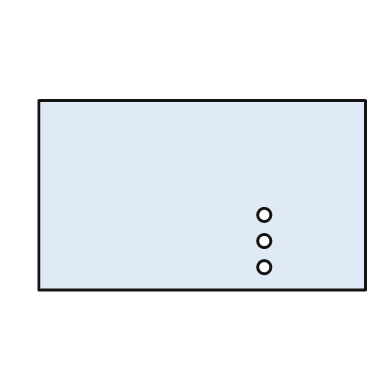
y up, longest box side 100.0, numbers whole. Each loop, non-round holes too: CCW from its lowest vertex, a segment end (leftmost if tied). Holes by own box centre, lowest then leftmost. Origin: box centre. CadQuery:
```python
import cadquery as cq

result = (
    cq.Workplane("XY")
    .moveTo(-50.0, -29.0)
    .lineTo(50.0, -29.0)
    .lineTo(50.0, 29.0)
    .lineTo(-50.0, 29.0)
    .close()
    .moveTo(19.0, -22.0)
    .circle(2.0)
    .moveTo(19.0, -14.0)
    .circle(2.0)
    .moveTo(19.0, -6.0)
    .circle(2.0)
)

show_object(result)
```